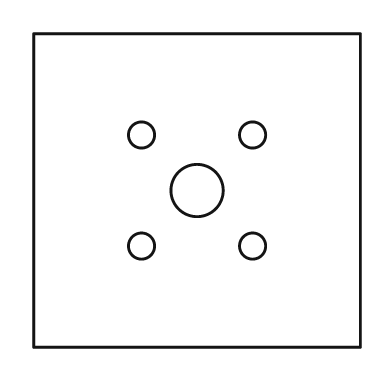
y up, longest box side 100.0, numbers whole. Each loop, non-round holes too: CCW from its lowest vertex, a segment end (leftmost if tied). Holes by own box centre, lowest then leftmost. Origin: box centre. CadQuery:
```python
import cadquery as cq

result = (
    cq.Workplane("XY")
    .moveTo(-50.0, -48.0)
    .lineTo(50.0, -48.0)
    .lineTo(50.0, 48.0)
    .lineTo(-50.0, 48.0)
    .close()
    .moveTo(-17.0, -17.0)
    .circle(4.0)
    .moveTo(17.0, -17.0)
    .circle(4.0)
    .moveTo(0.0, 0.0)
    .circle(8.0)
    .moveTo(-17.0, 17.0)
    .circle(4.0)
    .moveTo(17.0, 17.0)
    .circle(4.0)
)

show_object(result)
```